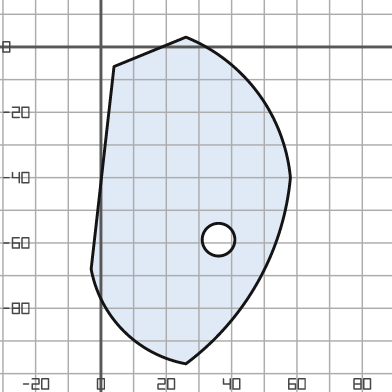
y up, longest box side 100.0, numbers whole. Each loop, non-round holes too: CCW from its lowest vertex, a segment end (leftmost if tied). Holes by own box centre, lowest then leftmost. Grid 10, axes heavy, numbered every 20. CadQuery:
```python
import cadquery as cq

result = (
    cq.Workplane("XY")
    .moveTo(26.0, -97.0)
    .threePointArc((48.0, -72.0), (58.0, -40.0))
    .threePointArc((48.0, -14.0), (26.0, 3.0))
    .lineTo(4.0, -6.0)
    .lineTo(-3.0, -68.0)
    .threePointArc((7.0, -87.0), (26.0, -97.0))
    .close()
    .moveTo(36.0, -59.0)
    .circle(5.0)
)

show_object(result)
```